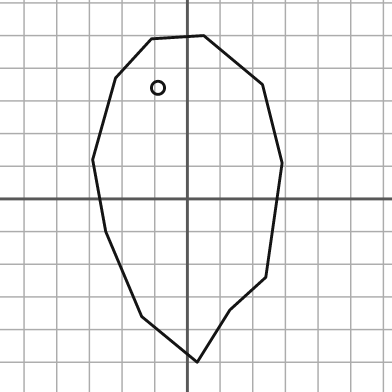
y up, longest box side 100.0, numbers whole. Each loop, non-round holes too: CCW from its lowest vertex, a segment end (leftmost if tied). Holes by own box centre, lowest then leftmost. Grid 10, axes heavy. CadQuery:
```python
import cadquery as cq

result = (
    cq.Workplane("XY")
    .moveTo(3.0, -50.0)
    .lineTo(13.0, -34.0)
    .lineTo(24.0, -24.0)
    .lineTo(29.0, 11.0)
    .lineTo(23.0, 35.0)
    .lineTo(5.0, 50.0)
    .lineTo(-11.0, 49.0)
    .lineTo(-22.0, 37.0)
    .lineTo(-29.0, 12.0)
    .lineTo(-25.0, -10.0)
    .lineTo(-14.0, -36.0)
    .close()
    .moveTo(-9.0, 34.0)
    .circle(2.0)
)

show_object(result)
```